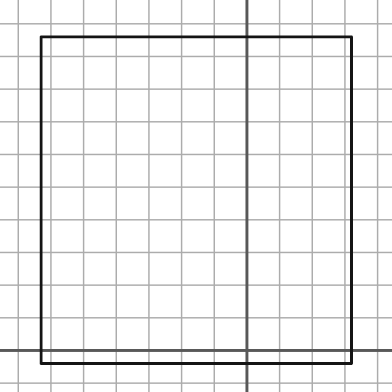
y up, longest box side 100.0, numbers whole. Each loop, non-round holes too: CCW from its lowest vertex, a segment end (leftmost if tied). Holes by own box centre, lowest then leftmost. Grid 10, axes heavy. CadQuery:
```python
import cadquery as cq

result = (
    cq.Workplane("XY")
    .moveTo(-63.0, -4.0)
    .lineTo(32.0, -4.0)
    .lineTo(32.0, 96.0)
    .lineTo(-63.0, 96.0)
    .close()
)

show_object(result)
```